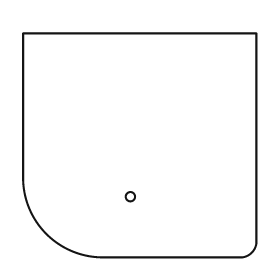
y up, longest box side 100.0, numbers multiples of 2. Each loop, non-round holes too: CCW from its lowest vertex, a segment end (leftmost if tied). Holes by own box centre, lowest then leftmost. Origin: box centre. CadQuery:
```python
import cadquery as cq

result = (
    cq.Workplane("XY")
    .moveTo(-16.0, -48.0)
    .lineTo(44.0, -48.0)
    .threePointArc((48.0, -46.0), (50.0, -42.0))
    .lineTo(50.0, 48.0)
    .lineTo(-50.0, 48.0)
    .lineTo(-50.0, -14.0)
    .threePointArc((-40.0, -38.0), (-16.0, -48.0))
    .close()
    .moveTo(-4.0, -22.0)
    .circle(2.0)
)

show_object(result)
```